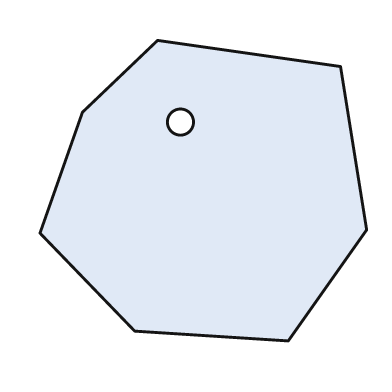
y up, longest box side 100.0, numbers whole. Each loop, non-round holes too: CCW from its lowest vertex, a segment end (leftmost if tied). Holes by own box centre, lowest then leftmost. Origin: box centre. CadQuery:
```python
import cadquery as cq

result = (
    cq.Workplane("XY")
    .moveTo(26.0, -46.0)
    .lineTo(50.0, -12.0)
    .lineTo(42.0, 38.0)
    .lineTo(-14.0, 46.0)
    .lineTo(-37.0, 24.0)
    .lineTo(-50.0, -13.0)
    .lineTo(-21.0, -43.0)
    .close()
    .moveTo(-7.0, 21.0)
    .circle(4.0)
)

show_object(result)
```